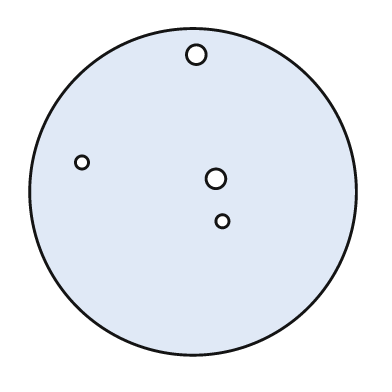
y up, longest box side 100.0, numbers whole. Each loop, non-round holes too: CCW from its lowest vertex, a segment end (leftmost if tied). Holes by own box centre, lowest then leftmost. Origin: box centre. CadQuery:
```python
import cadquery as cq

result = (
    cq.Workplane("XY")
    .moveTo(0.0, 0.0)
    .circle(50.0)
    .moveTo(9.0, -9.0)
    .circle(2.0)
    .moveTo(7.0, 4.0)
    .circle(3.0)
    .moveTo(-34.0, 9.0)
    .circle(2.0)
    .moveTo(1.0, 42.0)
    .circle(3.0)
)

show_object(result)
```